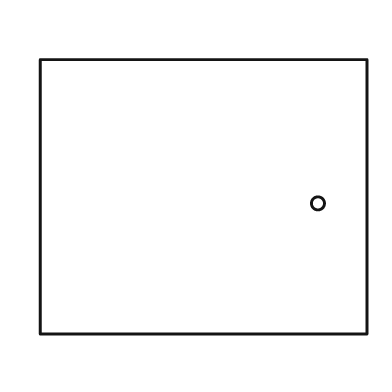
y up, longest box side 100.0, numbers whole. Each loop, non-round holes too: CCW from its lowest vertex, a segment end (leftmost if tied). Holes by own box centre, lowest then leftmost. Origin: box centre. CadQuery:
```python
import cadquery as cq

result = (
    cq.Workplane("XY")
    .moveTo(-50.0, -42.0)
    .lineTo(50.0, -42.0)
    .lineTo(50.0, 42.0)
    .lineTo(-50.0, 42.0)
    .close()
    .moveTo(35.0, -2.0)
    .circle(2.0)
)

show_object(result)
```